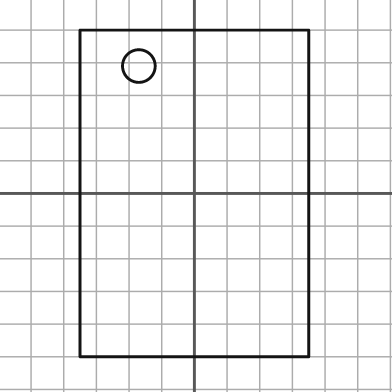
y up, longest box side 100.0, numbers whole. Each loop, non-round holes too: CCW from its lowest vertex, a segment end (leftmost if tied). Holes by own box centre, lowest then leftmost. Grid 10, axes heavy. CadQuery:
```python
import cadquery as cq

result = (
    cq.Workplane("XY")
    .moveTo(-35.0, -50.0)
    .lineTo(35.0, -50.0)
    .lineTo(35.0, 50.0)
    .lineTo(-35.0, 50.0)
    .close()
    .moveTo(-17.0, 39.0)
    .circle(5.0)
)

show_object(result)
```